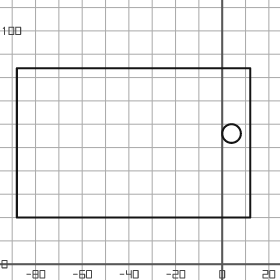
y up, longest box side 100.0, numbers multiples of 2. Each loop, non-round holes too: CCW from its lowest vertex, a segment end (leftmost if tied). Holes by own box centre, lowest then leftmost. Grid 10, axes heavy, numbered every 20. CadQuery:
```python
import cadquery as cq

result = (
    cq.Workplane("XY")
    .moveTo(-88.0, 20.0)
    .lineTo(12.0, 20.0)
    .lineTo(12.0, 84.0)
    .lineTo(-88.0, 84.0)
    .close()
    .moveTo(4.0, 56.0)
    .circle(4.0)
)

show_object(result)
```